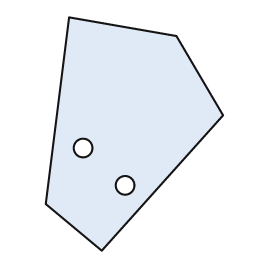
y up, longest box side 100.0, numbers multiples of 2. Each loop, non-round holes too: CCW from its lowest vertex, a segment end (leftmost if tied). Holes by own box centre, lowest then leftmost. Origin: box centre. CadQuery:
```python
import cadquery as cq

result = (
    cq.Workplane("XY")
    .moveTo(-14.0, -50.0)
    .lineTo(38.0, 8.0)
    .lineTo(18.0, 42.0)
    .lineTo(-28.0, 50.0)
    .lineTo(-38.0, -30.0)
    .close()
    .moveTo(-4.0, -22.0)
    .circle(4.0)
    .moveTo(-22.0, -6.0)
    .circle(4.0)
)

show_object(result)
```